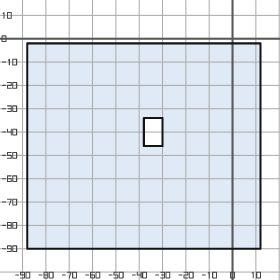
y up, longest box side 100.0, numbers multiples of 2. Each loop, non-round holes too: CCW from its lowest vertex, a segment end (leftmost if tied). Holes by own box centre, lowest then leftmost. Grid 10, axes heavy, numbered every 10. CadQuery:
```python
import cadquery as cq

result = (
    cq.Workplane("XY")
    .moveTo(-88.0, -90.0)
    .lineTo(12.0, -90.0)
    .lineTo(12.0, -2.0)
    .lineTo(-88.0, -2.0)
    .close()
    .moveTo(-38.0, -46.0)
    .lineTo(-30.0, -46.0)
    .lineTo(-30.0, -34.0)
    .lineTo(-38.0, -34.0)
    .close()
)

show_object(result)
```